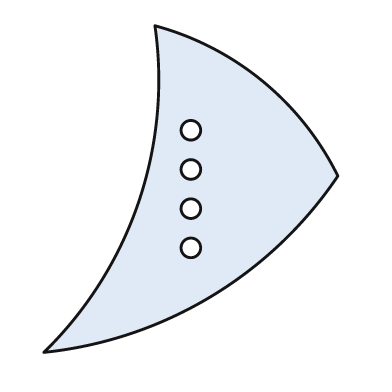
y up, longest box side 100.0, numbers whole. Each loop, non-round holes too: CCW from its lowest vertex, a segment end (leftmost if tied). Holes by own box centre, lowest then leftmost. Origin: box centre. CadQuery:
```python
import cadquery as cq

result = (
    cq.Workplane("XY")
    .moveTo(-45.0, -50.0)
    .threePointArc((6.0, -33.0), (45.0, 4.0))
    .threePointArc((22.0, 33.0), (-11.0, 50.0))
    .threePointArc((-16.0, -4.0), (-45.0, -50.0))
    .close()
    .moveTo(0.0, -18.0)
    .circle(3.0)
    .moveTo(0.0, -6.0)
    .circle(3.0)
    .moveTo(0.0, 6.0)
    .circle(3.0)
    .moveTo(0.0, 18.0)
    .circle(3.0)
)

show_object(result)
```